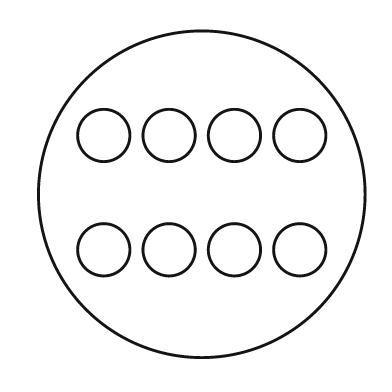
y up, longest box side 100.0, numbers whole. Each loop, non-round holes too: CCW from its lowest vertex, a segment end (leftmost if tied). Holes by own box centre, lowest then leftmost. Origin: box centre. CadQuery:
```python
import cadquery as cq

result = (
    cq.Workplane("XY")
    .moveTo(0.0, 0.0)
    .circle(50.0)
    .moveTo(-30.0, -17.0)
    .circle(8.0)
    .moveTo(-10.0, -17.0)
    .circle(8.0)
    .moveTo(10.0, -17.0)
    .circle(8.0)
    .moveTo(30.0, -17.0)
    .circle(8.0)
    .moveTo(-30.0, 18.0)
    .circle(8.0)
    .moveTo(-10.0, 18.0)
    .circle(8.0)
    .moveTo(10.0, 18.0)
    .circle(8.0)
    .moveTo(30.0, 18.0)
    .circle(8.0)
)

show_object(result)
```